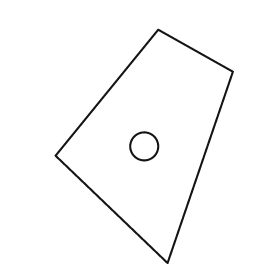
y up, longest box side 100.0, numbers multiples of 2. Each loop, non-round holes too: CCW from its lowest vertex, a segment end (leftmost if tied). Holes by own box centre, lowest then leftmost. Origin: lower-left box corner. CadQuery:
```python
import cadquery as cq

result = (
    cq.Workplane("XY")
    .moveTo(48.0, 0.0)
    .lineTo(76.0, 82.0)
    .lineTo(44.0, 100.0)
    .lineTo(0.0, 46.0)
    .close()
    .moveTo(38.0, 50.0)
    .circle(6.0)
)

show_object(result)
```